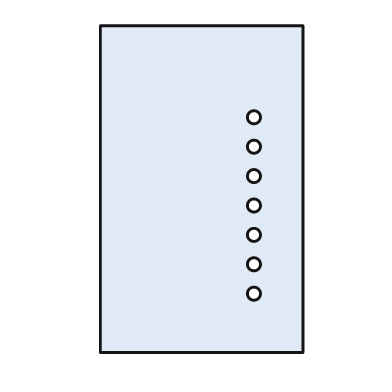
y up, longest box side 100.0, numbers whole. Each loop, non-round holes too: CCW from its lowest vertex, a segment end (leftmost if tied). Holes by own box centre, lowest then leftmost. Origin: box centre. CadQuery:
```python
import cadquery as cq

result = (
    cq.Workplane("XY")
    .moveTo(-31.0, -50.0)
    .lineTo(31.0, -50.0)
    .lineTo(31.0, 50.0)
    .lineTo(-31.0, 50.0)
    .close()
    .moveTo(16.0, -32.0)
    .circle(2.0)
    .moveTo(16.0, -23.0)
    .circle(2.0)
    .moveTo(16.0, -14.0)
    .circle(2.0)
    .moveTo(16.0, -5.0)
    .circle(2.0)
    .moveTo(16.0, 4.0)
    .circle(2.0)
    .moveTo(16.0, 13.0)
    .circle(2.0)
    .moveTo(16.0, 22.0)
    .circle(2.0)
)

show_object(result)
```